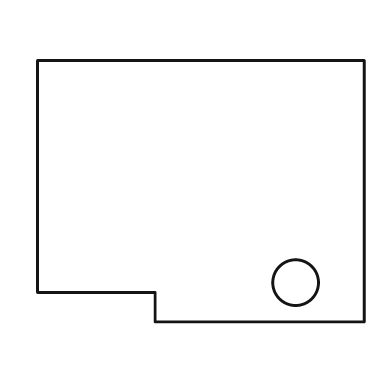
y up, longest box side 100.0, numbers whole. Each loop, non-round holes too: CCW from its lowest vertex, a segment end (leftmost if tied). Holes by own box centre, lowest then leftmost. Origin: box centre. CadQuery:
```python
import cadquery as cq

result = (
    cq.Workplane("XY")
    .moveTo(-14.0, -40.0)
    .lineTo(50.0, -40.0)
    .lineTo(50.0, 40.0)
    .lineTo(-50.0, 40.0)
    .lineTo(-50.0, -31.0)
    .lineTo(-14.0, -31.0)
    .close()
    .moveTo(29.0, -28.0)
    .circle(7.0)
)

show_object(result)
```